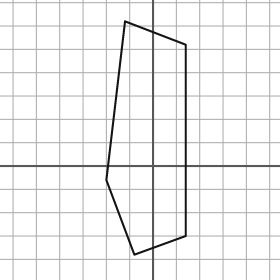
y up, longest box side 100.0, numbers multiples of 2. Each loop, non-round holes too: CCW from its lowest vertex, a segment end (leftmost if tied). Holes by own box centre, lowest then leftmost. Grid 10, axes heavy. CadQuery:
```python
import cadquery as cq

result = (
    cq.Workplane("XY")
    .moveTo(-8.0, -38.0)
    .lineTo(14.0, -30.0)
    .lineTo(14.0, 52.0)
    .lineTo(-12.0, 62.0)
    .lineTo(-20.0, -6.0)
    .close()
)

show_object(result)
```